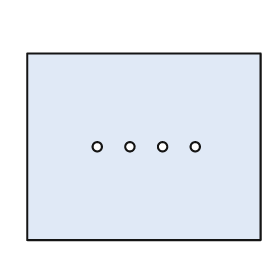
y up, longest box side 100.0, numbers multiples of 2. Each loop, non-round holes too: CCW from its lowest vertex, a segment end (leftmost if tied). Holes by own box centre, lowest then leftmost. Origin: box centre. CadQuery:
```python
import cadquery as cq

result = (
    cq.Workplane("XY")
    .moveTo(-50.0, -40.0)
    .lineTo(50.0, -40.0)
    .lineTo(50.0, 40.0)
    .lineTo(-50.0, 40.0)
    .close()
    .moveTo(-20.0, 0.0)
    .circle(2.0)
    .moveTo(-6.0, 0.0)
    .circle(2.0)
    .moveTo(8.0, 0.0)
    .circle(2.0)
    .moveTo(22.0, 0.0)
    .circle(2.0)
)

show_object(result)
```